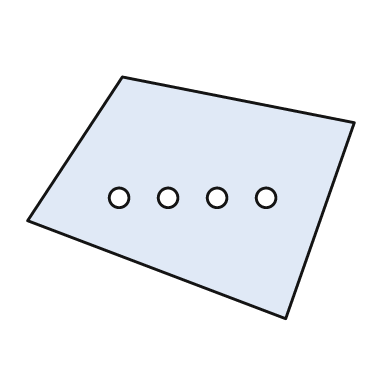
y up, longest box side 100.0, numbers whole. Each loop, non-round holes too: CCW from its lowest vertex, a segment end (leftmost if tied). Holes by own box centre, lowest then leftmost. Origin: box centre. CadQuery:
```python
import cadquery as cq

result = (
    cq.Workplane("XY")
    .moveTo(29.0, -37.0)
    .lineTo(50.0, 23.0)
    .lineTo(-21.0, 37.0)
    .lineTo(-50.0, -7.0)
    .close()
    .moveTo(-22.0, 0.0)
    .circle(3.0)
    .moveTo(-7.0, 0.0)
    .circle(3.0)
    .moveTo(8.0, 0.0)
    .circle(3.0)
    .moveTo(23.0, 0.0)
    .circle(3.0)
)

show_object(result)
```